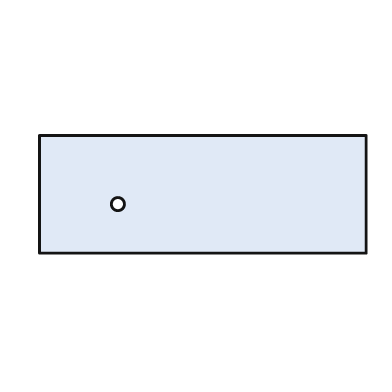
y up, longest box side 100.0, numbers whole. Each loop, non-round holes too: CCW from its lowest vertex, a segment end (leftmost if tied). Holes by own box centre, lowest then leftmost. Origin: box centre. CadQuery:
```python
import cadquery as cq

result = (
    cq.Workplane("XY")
    .moveTo(-50.0, -18.0)
    .lineTo(50.0, -18.0)
    .lineTo(50.0, 18.0)
    .lineTo(-50.0, 18.0)
    .close()
    .moveTo(-26.0, -3.0)
    .circle(2.0)
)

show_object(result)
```